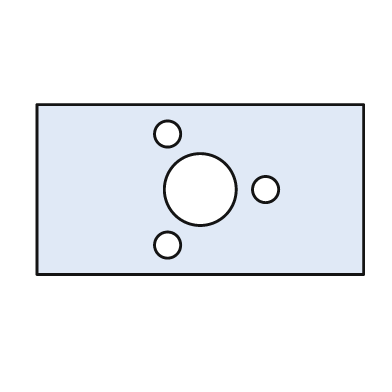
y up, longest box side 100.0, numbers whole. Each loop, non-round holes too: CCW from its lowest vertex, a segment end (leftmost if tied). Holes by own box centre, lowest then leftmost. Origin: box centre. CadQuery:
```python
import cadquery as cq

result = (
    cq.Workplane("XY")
    .moveTo(-50.0, -26.0)
    .lineTo(50.0, -26.0)
    .lineTo(50.0, 26.0)
    .lineTo(-50.0, 26.0)
    .close()
    .moveTo(-10.0, -17.0)
    .circle(4.0)
    .moveTo(0.0, 0.0)
    .circle(11.0)
    .moveTo(20.0, 0.0)
    .circle(4.0)
    .moveTo(-10.0, 17.0)
    .circle(4.0)
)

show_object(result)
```